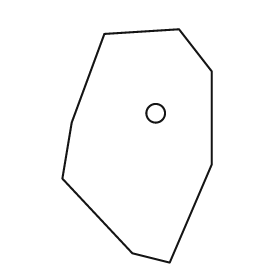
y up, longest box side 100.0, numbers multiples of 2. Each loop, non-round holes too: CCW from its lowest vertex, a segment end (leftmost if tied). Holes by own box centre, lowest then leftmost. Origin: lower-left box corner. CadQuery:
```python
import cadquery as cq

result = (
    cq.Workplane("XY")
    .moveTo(46.0, 0.0)
    .lineTo(64.0, 42.0)
    .lineTo(64.0, 82.0)
    .lineTo(50.0, 100.0)
    .lineTo(18.0, 98.0)
    .lineTo(4.0, 60.0)
    .lineTo(0.0, 36.0)
    .lineTo(30.0, 4.0)
    .close()
    .moveTo(40.0, 64.0)
    .circle(4.0)
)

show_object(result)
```